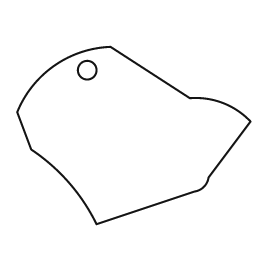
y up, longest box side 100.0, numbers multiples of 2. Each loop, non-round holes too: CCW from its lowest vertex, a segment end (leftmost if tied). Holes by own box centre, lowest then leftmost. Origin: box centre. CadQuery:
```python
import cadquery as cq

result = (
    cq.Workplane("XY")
    .moveTo(-16.0, -38.0)
    .lineTo(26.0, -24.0)
    .threePointArc((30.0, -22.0), (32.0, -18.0))
    .lineTo(50.0, 6.0)
    .threePointArc((38.0, 14.0), (24.0, 16.0))
    .lineTo(-10.0, 38.0)
    .threePointArc((-34.0, 30.0), (-50.0, 10.0))
    .lineTo(-44.0, -6.0)
    .threePointArc((-28.0, -20.0), (-16.0, -38.0))
    .close()
    .moveTo(-20.0, 28.0)
    .circle(4.0)
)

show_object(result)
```